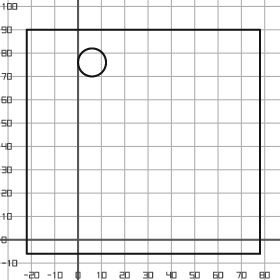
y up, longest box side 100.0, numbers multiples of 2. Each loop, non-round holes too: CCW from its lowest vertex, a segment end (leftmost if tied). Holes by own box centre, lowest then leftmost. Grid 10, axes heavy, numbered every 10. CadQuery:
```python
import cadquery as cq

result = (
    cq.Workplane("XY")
    .moveTo(-22.0, -6.0)
    .lineTo(78.0, -6.0)
    .lineTo(78.0, 90.0)
    .lineTo(-22.0, 90.0)
    .close()
    .moveTo(6.0, 76.0)
    .circle(6.0)
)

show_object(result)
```